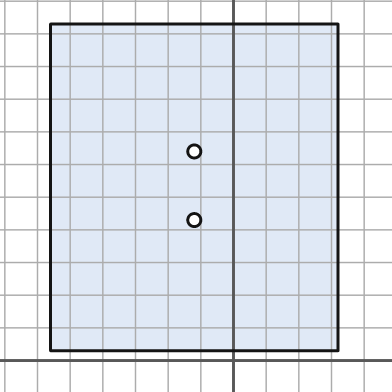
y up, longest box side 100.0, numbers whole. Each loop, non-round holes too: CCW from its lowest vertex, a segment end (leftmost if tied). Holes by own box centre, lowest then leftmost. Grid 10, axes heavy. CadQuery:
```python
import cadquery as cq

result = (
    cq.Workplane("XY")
    .moveTo(-56.0, 3.0)
    .lineTo(32.0, 3.0)
    .lineTo(32.0, 103.0)
    .lineTo(-56.0, 103.0)
    .close()
    .moveTo(-12.0, 43.0)
    .circle(2.0)
    .moveTo(-12.0, 64.0)
    .circle(2.0)
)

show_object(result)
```